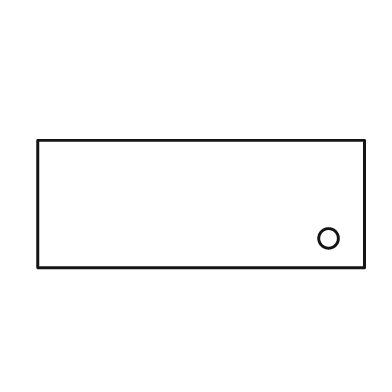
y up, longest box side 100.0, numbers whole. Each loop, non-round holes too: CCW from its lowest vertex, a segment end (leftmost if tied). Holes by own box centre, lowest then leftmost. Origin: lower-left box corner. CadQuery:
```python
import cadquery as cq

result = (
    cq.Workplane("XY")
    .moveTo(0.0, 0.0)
    .lineTo(100.0, 0.0)
    .lineTo(100.0, 39.0)
    .lineTo(0.0, 39.0)
    .close()
    .moveTo(89.0, 9.0)
    .circle(3.0)
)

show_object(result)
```